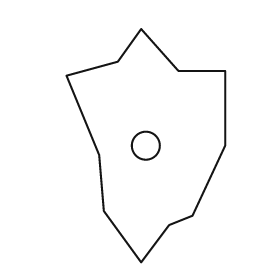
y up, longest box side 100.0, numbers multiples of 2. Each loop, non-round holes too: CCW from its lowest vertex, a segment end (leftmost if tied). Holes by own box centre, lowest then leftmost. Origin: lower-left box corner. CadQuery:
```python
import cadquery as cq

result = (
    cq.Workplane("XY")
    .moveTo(32.0, 0.0)
    .lineTo(44.0, 16.0)
    .lineTo(54.0, 20.0)
    .lineTo(68.0, 50.0)
    .lineTo(68.0, 82.0)
    .lineTo(48.0, 82.0)
    .lineTo(32.0, 100.0)
    .lineTo(22.0, 86.0)
    .lineTo(0.0, 80.0)
    .lineTo(14.0, 46.0)
    .lineTo(16.0, 22.0)
    .close()
    .moveTo(34.0, 50.0)
    .circle(6.0)
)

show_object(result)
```